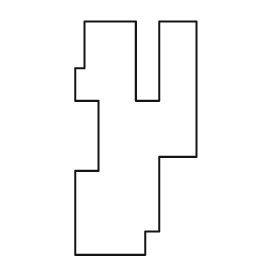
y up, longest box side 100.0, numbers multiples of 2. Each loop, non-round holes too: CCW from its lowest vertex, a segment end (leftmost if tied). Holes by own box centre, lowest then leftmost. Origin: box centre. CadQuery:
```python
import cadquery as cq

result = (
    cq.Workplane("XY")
    .moveTo(-26.0, -50.0)
    .lineTo(4.0, -50.0)
    .lineTo(4.0, -40.0)
    .lineTo(10.0, -40.0)
    .lineTo(10.0, -8.0)
    .lineTo(26.0, -8.0)
    .lineTo(26.0, 50.0)
    .lineTo(10.0, 50.0)
    .lineTo(10.0, 16.0)
    .lineTo(0.0, 16.0)
    .lineTo(0.0, 50.0)
    .lineTo(-22.0, 50.0)
    .lineTo(-22.0, 30.0)
    .lineTo(-26.0, 30.0)
    .lineTo(-26.0, 16.0)
    .lineTo(-16.0, 16.0)
    .lineTo(-16.0, -14.0)
    .lineTo(-26.0, -14.0)
    .close()
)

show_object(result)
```